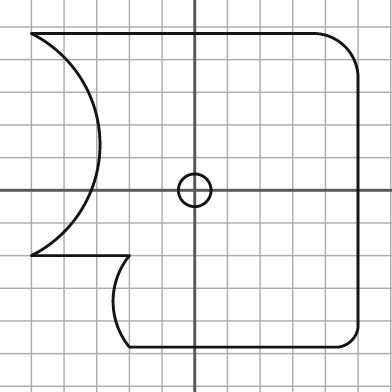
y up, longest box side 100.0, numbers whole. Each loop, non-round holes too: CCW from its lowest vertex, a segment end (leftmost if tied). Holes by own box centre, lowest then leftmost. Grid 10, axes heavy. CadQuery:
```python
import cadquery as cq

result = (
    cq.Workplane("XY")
    .moveTo(-20.0, -48.0)
    .lineTo(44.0, -48.0)
    .threePointArc((48.0, -46.0), (50.0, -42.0))
    .lineTo(50.0, 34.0)
    .threePointArc((46.0, 44.0), (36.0, 48.0))
    .lineTo(-50.0, 48.0)
    .threePointArc((-29.0, 14.0), (-50.0, -20.0))
    .lineTo(-20.0, -20.0)
    .threePointArc((-25.0, -34.0), (-20.0, -48.0))
    .close()
    .moveTo(0.0, 0.0)
    .circle(5.0)
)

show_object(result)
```